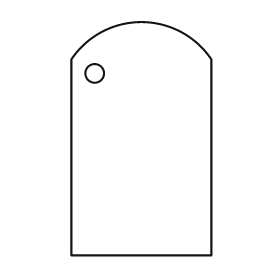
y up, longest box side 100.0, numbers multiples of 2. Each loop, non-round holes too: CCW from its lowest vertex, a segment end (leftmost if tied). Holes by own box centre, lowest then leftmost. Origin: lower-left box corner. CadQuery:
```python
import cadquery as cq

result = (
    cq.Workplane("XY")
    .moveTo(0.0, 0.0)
    .lineTo(60.0, 0.0)
    .lineTo(60.0, 84.0)
    .threePointArc((30.0, 100.0), (0.0, 84.0))
    .close()
    .moveTo(10.0, 78.0)
    .circle(4.0)
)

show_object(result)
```